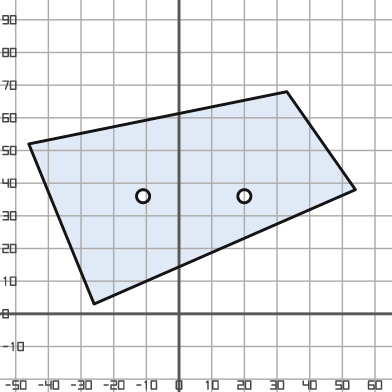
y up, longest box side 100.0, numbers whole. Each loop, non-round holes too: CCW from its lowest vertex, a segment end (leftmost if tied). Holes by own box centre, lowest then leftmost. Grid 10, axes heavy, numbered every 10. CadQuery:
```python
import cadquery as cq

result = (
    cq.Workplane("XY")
    .moveTo(-26.0, 3.0)
    .lineTo(54.0, 38.0)
    .lineTo(33.0, 68.0)
    .lineTo(-46.0, 52.0)
    .close()
    .moveTo(-11.0, 36.0)
    .circle(2.0)
    .moveTo(20.0, 36.0)
    .circle(2.0)
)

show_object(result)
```